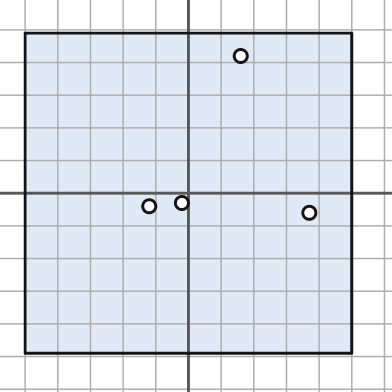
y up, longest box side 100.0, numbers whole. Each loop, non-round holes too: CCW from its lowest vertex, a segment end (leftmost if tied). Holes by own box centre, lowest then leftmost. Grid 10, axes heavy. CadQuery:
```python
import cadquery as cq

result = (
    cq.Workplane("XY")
    .moveTo(-50.0, -49.0)
    .lineTo(50.0, -49.0)
    .lineTo(50.0, 49.0)
    .lineTo(-50.0, 49.0)
    .close()
    .moveTo(37.0, -6.0)
    .circle(2.0)
    .moveTo(-12.0, -4.0)
    .circle(2.0)
    .moveTo(-2.0, -3.0)
    .circle(2.0)
    .moveTo(16.0, 42.0)
    .circle(2.0)
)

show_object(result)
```